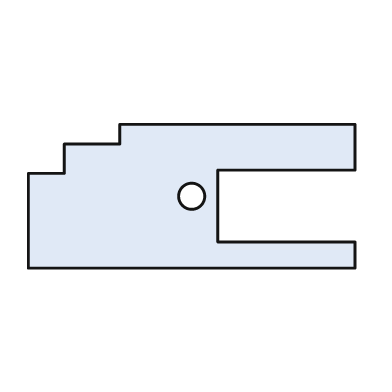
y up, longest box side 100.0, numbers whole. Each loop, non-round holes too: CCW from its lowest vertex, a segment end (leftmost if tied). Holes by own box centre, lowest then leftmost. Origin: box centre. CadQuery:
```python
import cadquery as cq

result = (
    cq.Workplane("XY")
    .moveTo(-50.0, -22.0)
    .lineTo(50.0, -22.0)
    .lineTo(50.0, -14.0)
    .lineTo(8.0, -14.0)
    .lineTo(8.0, 8.0)
    .lineTo(50.0, 8.0)
    .lineTo(50.0, 22.0)
    .lineTo(-22.0, 22.0)
    .lineTo(-22.0, 16.0)
    .lineTo(-39.0, 16.0)
    .lineTo(-39.0, 7.0)
    .lineTo(-50.0, 7.0)
    .close()
    .moveTo(0.0, 0.0)
    .circle(4.0)
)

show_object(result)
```